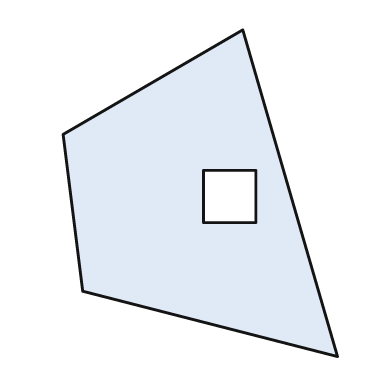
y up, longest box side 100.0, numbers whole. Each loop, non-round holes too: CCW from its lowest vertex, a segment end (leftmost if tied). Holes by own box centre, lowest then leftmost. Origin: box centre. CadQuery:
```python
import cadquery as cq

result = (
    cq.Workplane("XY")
    .moveTo(42.0, -50.0)
    .lineTo(13.0, 50.0)
    .lineTo(-42.0, 18.0)
    .lineTo(-36.0, -30.0)
    .close()
    .moveTo(1.0, -9.0)
    .lineTo(17.0, -9.0)
    .lineTo(17.0, 7.0)
    .lineTo(1.0, 7.0)
    .close()
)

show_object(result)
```